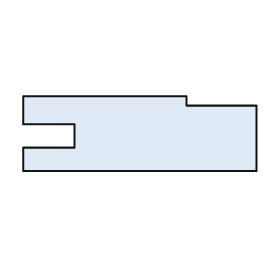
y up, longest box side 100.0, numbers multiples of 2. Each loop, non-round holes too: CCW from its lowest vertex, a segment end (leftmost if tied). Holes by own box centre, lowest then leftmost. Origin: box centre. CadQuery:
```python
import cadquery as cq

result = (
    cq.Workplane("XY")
    .moveTo(-50.0, -16.0)
    .lineTo(50.0, -16.0)
    .lineTo(50.0, 12.0)
    .lineTo(20.0, 12.0)
    .lineTo(20.0, 16.0)
    .lineTo(-50.0, 16.0)
    .lineTo(-50.0, 4.0)
    .lineTo(-28.0, 4.0)
    .lineTo(-28.0, -6.0)
    .lineTo(-50.0, -6.0)
    .close()
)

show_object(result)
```